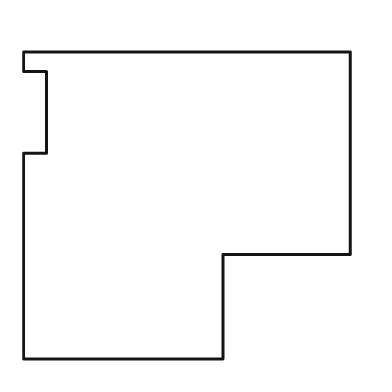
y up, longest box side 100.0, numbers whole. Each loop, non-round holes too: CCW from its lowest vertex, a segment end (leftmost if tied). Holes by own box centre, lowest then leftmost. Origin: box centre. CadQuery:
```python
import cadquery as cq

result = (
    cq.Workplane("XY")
    .moveTo(-50.0, -47.0)
    .lineTo(11.0, -47.0)
    .lineTo(11.0, -15.0)
    .lineTo(50.0, -15.0)
    .lineTo(50.0, 47.0)
    .lineTo(-50.0, 47.0)
    .lineTo(-50.0, 41.0)
    .lineTo(-43.0, 41.0)
    .lineTo(-43.0, 16.0)
    .lineTo(-50.0, 16.0)
    .close()
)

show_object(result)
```